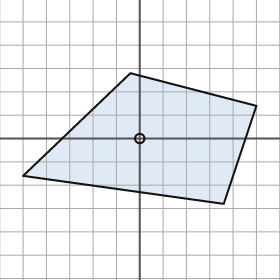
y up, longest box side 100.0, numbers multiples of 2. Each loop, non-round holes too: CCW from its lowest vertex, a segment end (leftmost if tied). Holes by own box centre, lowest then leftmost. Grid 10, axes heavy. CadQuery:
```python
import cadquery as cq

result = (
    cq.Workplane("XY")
    .moveTo(36.0, -28.0)
    .lineTo(50.0, 14.0)
    .lineTo(-4.0, 28.0)
    .lineTo(-50.0, -16.0)
    .close()
    .moveTo(0.0, 0.0)
    .circle(2.0)
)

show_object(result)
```